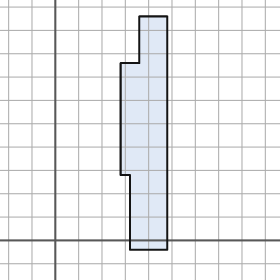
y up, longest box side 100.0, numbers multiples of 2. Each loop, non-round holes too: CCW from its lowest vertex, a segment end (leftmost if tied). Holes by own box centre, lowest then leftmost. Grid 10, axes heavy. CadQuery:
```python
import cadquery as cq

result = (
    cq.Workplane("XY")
    .moveTo(32.0, -4.0)
    .lineTo(48.0, -4.0)
    .lineTo(48.0, 96.0)
    .lineTo(36.0, 96.0)
    .lineTo(36.0, 76.0)
    .lineTo(28.0, 76.0)
    .lineTo(28.0, 28.0)
    .lineTo(32.0, 28.0)
    .close()
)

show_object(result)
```